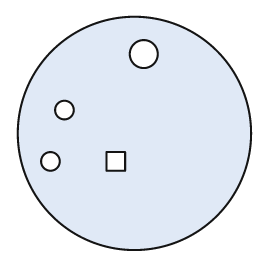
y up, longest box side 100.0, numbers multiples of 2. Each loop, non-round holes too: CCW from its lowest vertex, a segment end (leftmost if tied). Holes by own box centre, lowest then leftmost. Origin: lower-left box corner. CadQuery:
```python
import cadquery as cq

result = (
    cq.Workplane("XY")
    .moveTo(50.0, 50.0)
    .circle(50.0)
    .moveTo(14.0, 38.0)
    .circle(4.0)
    .moveTo(38.0, 34.0)
    .lineTo(46.0, 34.0)
    .lineTo(46.0, 42.0)
    .lineTo(38.0, 42.0)
    .close()
    .moveTo(20.0, 60.0)
    .circle(4.0)
    .moveTo(54.0, 84.0)
    .circle(6.0)
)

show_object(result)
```